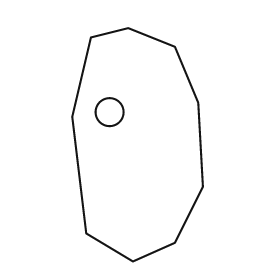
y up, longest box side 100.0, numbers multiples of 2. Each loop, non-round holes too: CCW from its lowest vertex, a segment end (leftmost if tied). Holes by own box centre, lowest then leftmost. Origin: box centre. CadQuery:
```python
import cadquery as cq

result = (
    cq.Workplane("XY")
    .moveTo(-2.0, -50.0)
    .lineTo(16.0, -42.0)
    .lineTo(28.0, -18.0)
    .lineTo(26.0, 18.0)
    .lineTo(16.0, 42.0)
    .lineTo(-4.0, 50.0)
    .lineTo(-20.0, 46.0)
    .lineTo(-28.0, 12.0)
    .lineTo(-22.0, -38.0)
    .close()
    .moveTo(-12.0, 14.0)
    .circle(6.0)
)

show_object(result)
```